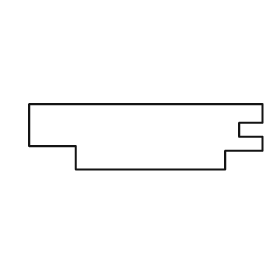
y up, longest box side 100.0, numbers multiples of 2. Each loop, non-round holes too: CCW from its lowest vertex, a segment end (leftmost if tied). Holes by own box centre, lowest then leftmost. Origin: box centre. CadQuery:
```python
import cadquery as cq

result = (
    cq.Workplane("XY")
    .moveTo(-30.0, -14.0)
    .lineTo(34.0, -14.0)
    .lineTo(34.0, -6.0)
    .lineTo(50.0, -6.0)
    .lineTo(50.0, 0.0)
    .lineTo(40.0, 0.0)
    .lineTo(40.0, 6.0)
    .lineTo(50.0, 6.0)
    .lineTo(50.0, 14.0)
    .lineTo(-50.0, 14.0)
    .lineTo(-50.0, -4.0)
    .lineTo(-30.0, -4.0)
    .close()
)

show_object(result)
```